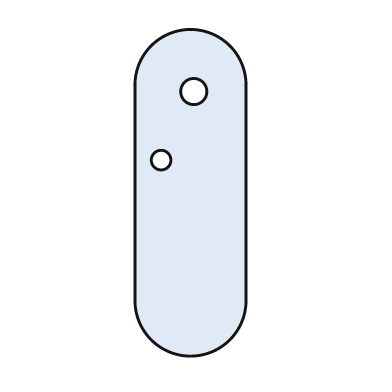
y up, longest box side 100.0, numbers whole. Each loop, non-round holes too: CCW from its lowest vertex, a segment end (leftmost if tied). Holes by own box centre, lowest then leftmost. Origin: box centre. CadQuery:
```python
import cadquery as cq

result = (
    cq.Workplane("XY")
    .moveTo(-17.0, -33.0)
    .threePointArc((0.0, -50.0), (17.0, -33.0))
    .lineTo(17.0, 33.0)
    .threePointArc((0.0, 50.0), (-17.0, 33.0))
    .close()
    .moveTo(-9.0, 10.0)
    .circle(3.0)
    .moveTo(1.0, 31.0)
    .circle(4.0)
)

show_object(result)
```